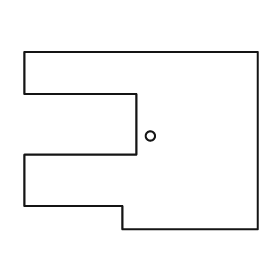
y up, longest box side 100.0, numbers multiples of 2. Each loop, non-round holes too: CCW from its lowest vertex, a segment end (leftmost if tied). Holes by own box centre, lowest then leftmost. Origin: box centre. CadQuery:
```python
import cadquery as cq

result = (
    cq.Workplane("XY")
    .moveTo(-8.0, -38.0)
    .lineTo(50.0, -38.0)
    .lineTo(50.0, 38.0)
    .lineTo(-50.0, 38.0)
    .lineTo(-50.0, 20.0)
    .lineTo(-2.0, 20.0)
    .lineTo(-2.0, -6.0)
    .lineTo(-50.0, -6.0)
    .lineTo(-50.0, -28.0)
    .lineTo(-8.0, -28.0)
    .close()
    .moveTo(4.0, 2.0)
    .circle(2.0)
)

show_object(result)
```